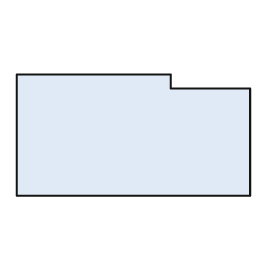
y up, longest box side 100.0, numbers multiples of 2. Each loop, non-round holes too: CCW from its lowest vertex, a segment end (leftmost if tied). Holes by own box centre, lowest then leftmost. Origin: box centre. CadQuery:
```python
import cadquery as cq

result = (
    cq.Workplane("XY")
    .moveTo(-50.0, -26.0)
    .lineTo(50.0, -26.0)
    .lineTo(50.0, 20.0)
    .lineTo(16.0, 20.0)
    .lineTo(16.0, 26.0)
    .lineTo(-50.0, 26.0)
    .close()
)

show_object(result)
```